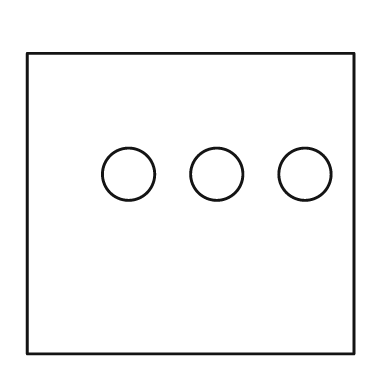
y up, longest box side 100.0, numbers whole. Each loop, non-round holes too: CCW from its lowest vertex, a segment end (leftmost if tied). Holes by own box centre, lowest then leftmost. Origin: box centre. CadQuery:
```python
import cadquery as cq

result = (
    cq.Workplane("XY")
    .moveTo(-50.0, -46.0)
    .lineTo(50.0, -46.0)
    .lineTo(50.0, 46.0)
    .lineTo(-50.0, 46.0)
    .close()
    .moveTo(-19.0, 9.0)
    .circle(8.0)
    .moveTo(8.0, 9.0)
    .circle(8.0)
    .moveTo(35.0, 9.0)
    .circle(8.0)
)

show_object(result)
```